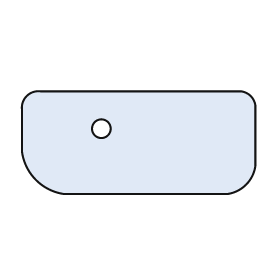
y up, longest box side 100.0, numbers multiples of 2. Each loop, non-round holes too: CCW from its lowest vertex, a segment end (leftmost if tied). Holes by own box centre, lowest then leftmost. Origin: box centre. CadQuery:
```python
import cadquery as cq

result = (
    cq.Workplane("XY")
    .moveTo(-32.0, -22.0)
    .lineTo(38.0, -22.0)
    .threePointArc((46.0, -18.0), (50.0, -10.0))
    .lineTo(50.0, 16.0)
    .threePointArc((48.0, 20.0), (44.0, 22.0))
    .lineTo(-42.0, 22.0)
    .threePointArc((-48.0, 20.0), (-50.0, 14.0))
    .lineTo(-50.0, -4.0)
    .threePointArc((-44.0, -16.0), (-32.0, -22.0))
    .close()
    .moveTo(-16.0, 6.0)
    .circle(4.0)
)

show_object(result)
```